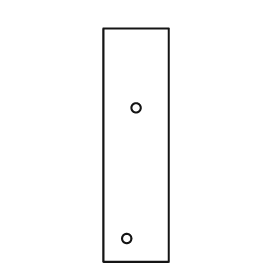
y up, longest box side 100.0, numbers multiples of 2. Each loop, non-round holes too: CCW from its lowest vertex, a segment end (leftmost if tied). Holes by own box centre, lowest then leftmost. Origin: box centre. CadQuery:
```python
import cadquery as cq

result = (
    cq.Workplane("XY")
    .moveTo(-14.0, -50.0)
    .lineTo(14.0, -50.0)
    .lineTo(14.0, 50.0)
    .lineTo(-14.0, 50.0)
    .close()
    .moveTo(-4.0, -40.0)
    .circle(2.0)
    .moveTo(0.0, 16.0)
    .circle(2.0)
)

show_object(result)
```